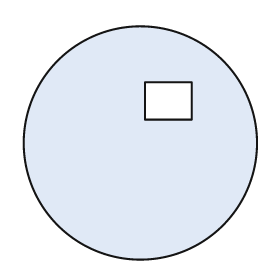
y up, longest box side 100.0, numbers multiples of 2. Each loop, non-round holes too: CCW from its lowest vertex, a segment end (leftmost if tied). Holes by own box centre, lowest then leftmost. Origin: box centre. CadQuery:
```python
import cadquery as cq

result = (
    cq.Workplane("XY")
    .moveTo(0.0, 0.0)
    .circle(50.0)
    .moveTo(2.0, 10.0)
    .lineTo(22.0, 10.0)
    .lineTo(22.0, 26.0)
    .lineTo(2.0, 26.0)
    .close()
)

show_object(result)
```